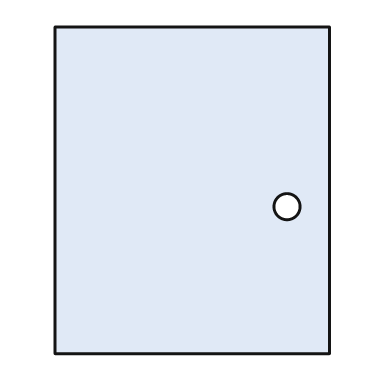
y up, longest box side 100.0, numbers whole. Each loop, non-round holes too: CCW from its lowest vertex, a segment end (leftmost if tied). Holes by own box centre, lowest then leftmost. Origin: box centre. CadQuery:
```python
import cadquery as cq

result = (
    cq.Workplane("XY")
    .moveTo(-42.0, -50.0)
    .lineTo(42.0, -50.0)
    .lineTo(42.0, 50.0)
    .lineTo(-42.0, 50.0)
    .close()
    .moveTo(29.0, -5.0)
    .circle(4.0)
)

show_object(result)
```